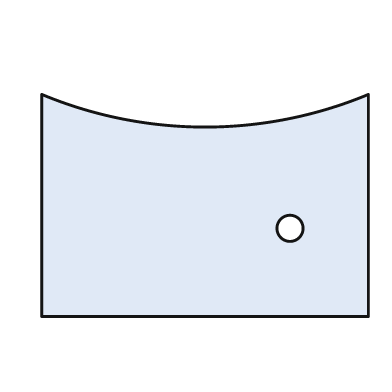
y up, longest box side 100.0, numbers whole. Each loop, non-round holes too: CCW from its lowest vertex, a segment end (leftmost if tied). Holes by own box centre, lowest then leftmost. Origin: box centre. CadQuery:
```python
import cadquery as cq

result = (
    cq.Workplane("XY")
    .moveTo(-50.0, -34.0)
    .lineTo(50.0, -34.0)
    .lineTo(50.0, 34.0)
    .threePointArc((0.0, 24.0), (-50.0, 34.0))
    .close()
    .moveTo(26.0, -7.0)
    .circle(4.0)
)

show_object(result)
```